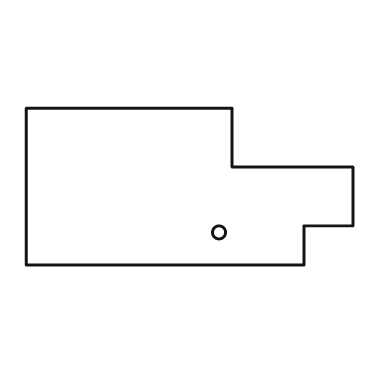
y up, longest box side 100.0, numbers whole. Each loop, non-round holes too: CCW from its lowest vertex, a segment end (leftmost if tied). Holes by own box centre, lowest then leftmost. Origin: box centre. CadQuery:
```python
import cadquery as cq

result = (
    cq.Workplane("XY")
    .moveTo(-50.0, -24.0)
    .lineTo(35.0, -24.0)
    .lineTo(35.0, -12.0)
    .lineTo(50.0, -12.0)
    .lineTo(50.0, 6.0)
    .lineTo(13.0, 6.0)
    .lineTo(13.0, 24.0)
    .lineTo(-50.0, 24.0)
    .close()
    .moveTo(9.0, -14.0)
    .circle(2.0)
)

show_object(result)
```